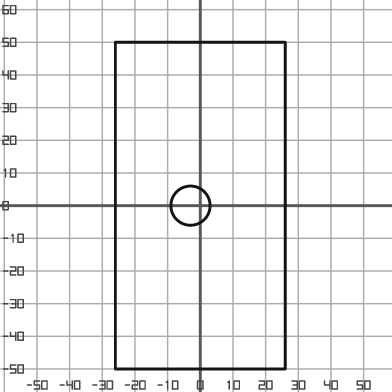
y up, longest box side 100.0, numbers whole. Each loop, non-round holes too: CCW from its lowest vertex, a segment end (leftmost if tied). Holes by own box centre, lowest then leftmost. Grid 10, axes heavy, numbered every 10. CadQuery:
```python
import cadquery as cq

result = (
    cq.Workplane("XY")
    .moveTo(-26.0, -50.0)
    .lineTo(26.0, -50.0)
    .lineTo(26.0, 50.0)
    .lineTo(-26.0, 50.0)
    .close()
    .moveTo(-3.0, 0.0)
    .circle(6.0)
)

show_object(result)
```